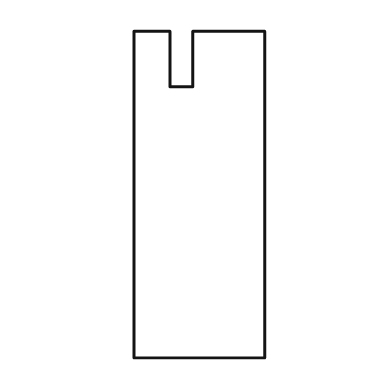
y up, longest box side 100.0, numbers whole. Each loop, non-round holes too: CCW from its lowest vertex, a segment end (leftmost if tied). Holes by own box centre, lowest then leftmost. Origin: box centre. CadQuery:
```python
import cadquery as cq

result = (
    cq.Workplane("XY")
    .moveTo(-20.0, -50.0)
    .lineTo(20.0, -50.0)
    .lineTo(20.0, 50.0)
    .lineTo(-2.0, 50.0)
    .lineTo(-2.0, 33.0)
    .lineTo(-9.0, 33.0)
    .lineTo(-9.0, 50.0)
    .lineTo(-20.0, 50.0)
    .close()
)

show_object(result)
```